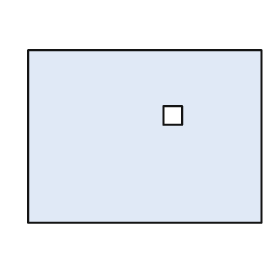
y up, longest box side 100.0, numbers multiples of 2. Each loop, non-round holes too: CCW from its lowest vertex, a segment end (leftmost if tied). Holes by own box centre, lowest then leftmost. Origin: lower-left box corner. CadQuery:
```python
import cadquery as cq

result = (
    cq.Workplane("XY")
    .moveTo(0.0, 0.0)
    .lineTo(100.0, 0.0)
    .lineTo(100.0, 74.0)
    .lineTo(0.0, 74.0)
    .close()
    .moveTo(58.0, 42.0)
    .lineTo(66.0, 42.0)
    .lineTo(66.0, 50.0)
    .lineTo(58.0, 50.0)
    .close()
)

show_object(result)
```